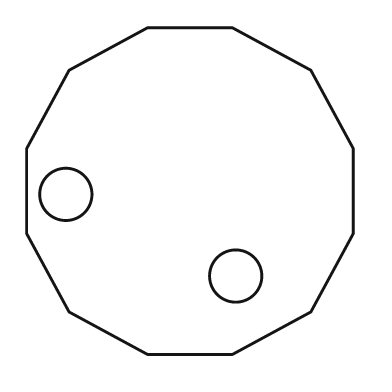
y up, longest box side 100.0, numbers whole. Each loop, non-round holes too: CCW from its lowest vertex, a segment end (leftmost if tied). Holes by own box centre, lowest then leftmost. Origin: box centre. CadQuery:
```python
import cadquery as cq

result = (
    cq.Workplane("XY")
    .moveTo(-13.0, -50.0)
    .lineTo(13.0, -50.0)
    .lineTo(37.0, -37.0)
    .lineTo(50.0, -13.0)
    .lineTo(50.0, 13.0)
    .lineTo(37.0, 37.0)
    .lineTo(13.0, 50.0)
    .lineTo(-13.0, 50.0)
    .lineTo(-37.0, 37.0)
    .lineTo(-50.0, 13.0)
    .lineTo(-50.0, -13.0)
    .lineTo(-37.0, -37.0)
    .close()
    .moveTo(14.0, -26.0)
    .circle(8.0)
    .moveTo(-38.0, -1.0)
    .circle(8.0)
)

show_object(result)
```